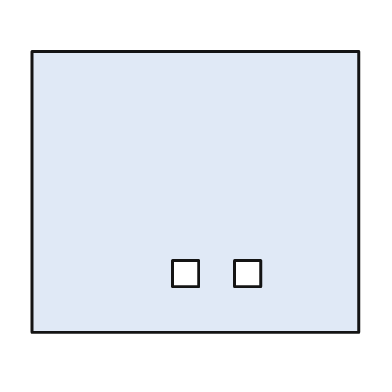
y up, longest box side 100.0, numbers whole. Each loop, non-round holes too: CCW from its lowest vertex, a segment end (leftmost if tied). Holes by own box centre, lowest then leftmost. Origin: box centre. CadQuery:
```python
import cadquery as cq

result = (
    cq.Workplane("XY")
    .moveTo(-50.0, -43.0)
    .lineTo(50.0, -43.0)
    .lineTo(50.0, 43.0)
    .lineTo(-50.0, 43.0)
    .close()
    .moveTo(-7.0, -29.0)
    .lineTo(1.0, -29.0)
    .lineTo(1.0, -21.0)
    .lineTo(-7.0, -21.0)
    .close()
    .moveTo(12.0, -29.0)
    .lineTo(20.0, -29.0)
    .lineTo(20.0, -21.0)
    .lineTo(12.0, -21.0)
    .close()
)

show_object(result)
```